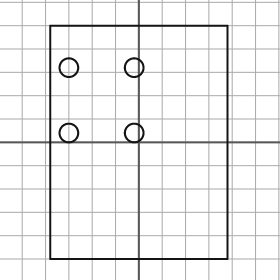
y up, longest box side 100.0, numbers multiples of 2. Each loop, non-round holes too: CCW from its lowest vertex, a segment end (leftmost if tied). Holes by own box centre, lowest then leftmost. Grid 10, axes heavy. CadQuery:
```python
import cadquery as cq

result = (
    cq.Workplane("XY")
    .moveTo(-38.0, -50.0)
    .lineTo(38.0, -50.0)
    .lineTo(38.0, 50.0)
    .lineTo(-38.0, 50.0)
    .close()
    .moveTo(-30.0, 4.0)
    .circle(4.0)
    .moveTo(-2.0, 4.0)
    .circle(4.0)
    .moveTo(-30.0, 32.0)
    .circle(4.0)
    .moveTo(-2.0, 32.0)
    .circle(4.0)
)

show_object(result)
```